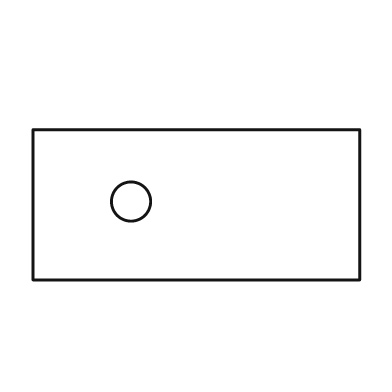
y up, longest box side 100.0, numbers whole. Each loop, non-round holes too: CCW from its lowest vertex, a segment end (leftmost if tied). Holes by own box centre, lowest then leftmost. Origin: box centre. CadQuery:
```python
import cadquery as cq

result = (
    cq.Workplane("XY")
    .moveTo(-50.0, -23.0)
    .lineTo(50.0, -23.0)
    .lineTo(50.0, 23.0)
    .lineTo(-50.0, 23.0)
    .close()
    .moveTo(-20.0, 1.0)
    .circle(6.0)
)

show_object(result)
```